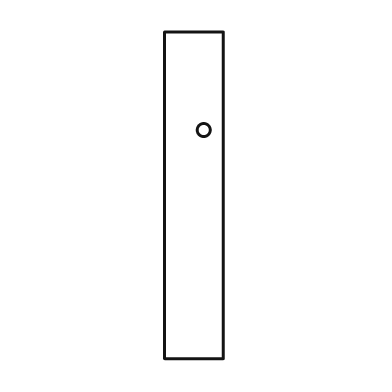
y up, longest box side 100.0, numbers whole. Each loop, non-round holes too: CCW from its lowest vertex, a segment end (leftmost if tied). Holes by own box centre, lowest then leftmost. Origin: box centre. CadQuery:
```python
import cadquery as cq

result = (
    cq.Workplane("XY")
    .moveTo(-9.0, -50.0)
    .lineTo(9.0, -50.0)
    .lineTo(9.0, 50.0)
    .lineTo(-9.0, 50.0)
    .close()
    .moveTo(3.0, 20.0)
    .circle(2.0)
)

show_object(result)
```